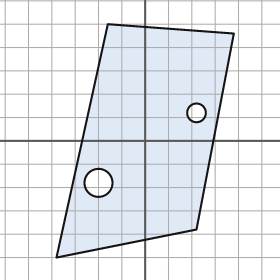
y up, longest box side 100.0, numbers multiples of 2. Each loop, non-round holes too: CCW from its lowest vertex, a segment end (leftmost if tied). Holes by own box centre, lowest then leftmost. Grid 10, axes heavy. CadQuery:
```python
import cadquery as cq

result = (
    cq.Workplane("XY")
    .moveTo(-38.0, -50.0)
    .lineTo(22.0, -38.0)
    .lineTo(38.0, 46.0)
    .lineTo(-16.0, 50.0)
    .close()
    .moveTo(-20.0, -18.0)
    .circle(6.0)
    .moveTo(22.0, 12.0)
    .circle(4.0)
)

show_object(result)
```